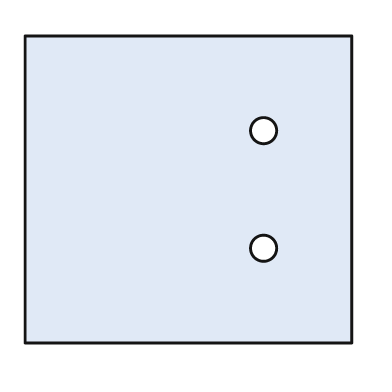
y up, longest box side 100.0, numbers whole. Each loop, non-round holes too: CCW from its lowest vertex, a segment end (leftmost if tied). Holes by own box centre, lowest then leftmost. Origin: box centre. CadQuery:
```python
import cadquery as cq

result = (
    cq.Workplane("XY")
    .moveTo(-50.0, -47.0)
    .lineTo(50.0, -47.0)
    .lineTo(50.0, 47.0)
    .lineTo(-50.0, 47.0)
    .close()
    .moveTo(23.0, -18.0)
    .circle(4.0)
    .moveTo(23.0, 18.0)
    .circle(4.0)
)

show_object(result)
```